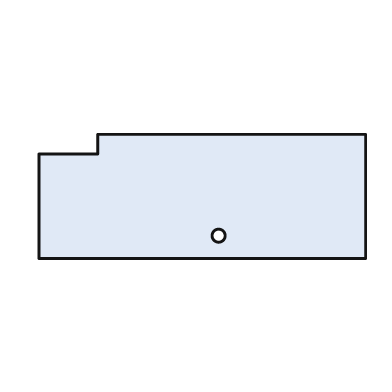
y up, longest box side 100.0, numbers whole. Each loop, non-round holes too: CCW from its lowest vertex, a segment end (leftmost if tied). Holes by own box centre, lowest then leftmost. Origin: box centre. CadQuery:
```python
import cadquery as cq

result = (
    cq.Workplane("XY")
    .moveTo(-50.0, -19.0)
    .lineTo(50.0, -19.0)
    .lineTo(50.0, 19.0)
    .lineTo(-32.0, 19.0)
    .lineTo(-32.0, 13.0)
    .lineTo(-50.0, 13.0)
    .close()
    .moveTo(5.0, -12.0)
    .circle(2.0)
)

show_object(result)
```